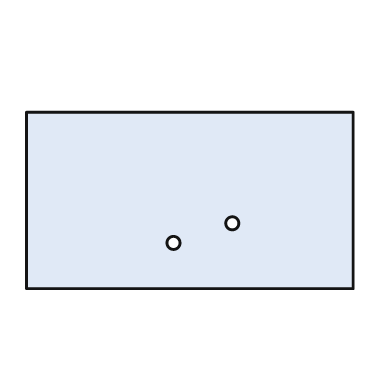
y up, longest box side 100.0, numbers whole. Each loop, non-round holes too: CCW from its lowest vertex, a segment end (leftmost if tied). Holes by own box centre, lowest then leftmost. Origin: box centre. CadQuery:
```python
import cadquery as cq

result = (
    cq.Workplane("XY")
    .moveTo(-50.0, -27.0)
    .lineTo(50.0, -27.0)
    .lineTo(50.0, 27.0)
    .lineTo(-50.0, 27.0)
    .close()
    .moveTo(-5.0, -13.0)
    .circle(2.0)
    .moveTo(13.0, -7.0)
    .circle(2.0)
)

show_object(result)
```